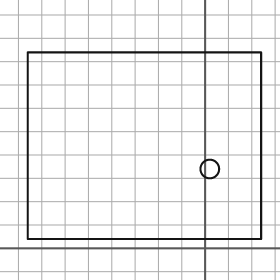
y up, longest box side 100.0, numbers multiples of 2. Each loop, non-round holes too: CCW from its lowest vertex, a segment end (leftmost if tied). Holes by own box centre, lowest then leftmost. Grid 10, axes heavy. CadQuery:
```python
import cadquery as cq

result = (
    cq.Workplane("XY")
    .moveTo(-76.0, 4.0)
    .lineTo(24.0, 4.0)
    .lineTo(24.0, 84.0)
    .lineTo(-76.0, 84.0)
    .close()
    .moveTo(2.0, 34.0)
    .circle(4.0)
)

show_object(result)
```